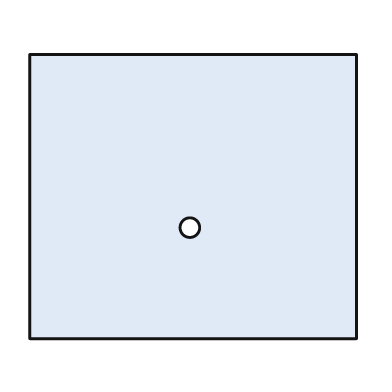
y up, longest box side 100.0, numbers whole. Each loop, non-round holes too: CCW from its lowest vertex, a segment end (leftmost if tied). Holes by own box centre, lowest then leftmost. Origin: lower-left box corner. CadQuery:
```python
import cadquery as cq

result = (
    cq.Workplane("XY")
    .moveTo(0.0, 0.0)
    .lineTo(100.0, 0.0)
    .lineTo(100.0, 87.0)
    .lineTo(0.0, 87.0)
    .close()
    .moveTo(49.0, 34.0)
    .circle(3.0)
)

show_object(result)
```